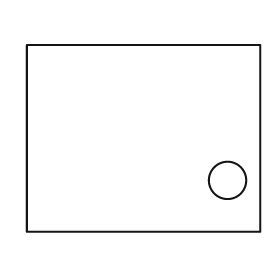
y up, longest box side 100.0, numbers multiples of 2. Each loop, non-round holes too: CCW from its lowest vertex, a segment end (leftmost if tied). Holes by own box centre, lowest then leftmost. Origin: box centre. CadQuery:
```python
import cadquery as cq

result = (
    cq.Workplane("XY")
    .moveTo(-50.0, -40.0)
    .lineTo(50.0, -40.0)
    .lineTo(50.0, 40.0)
    .lineTo(-50.0, 40.0)
    .close()
    .moveTo(36.0, -18.0)
    .circle(8.0)
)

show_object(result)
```